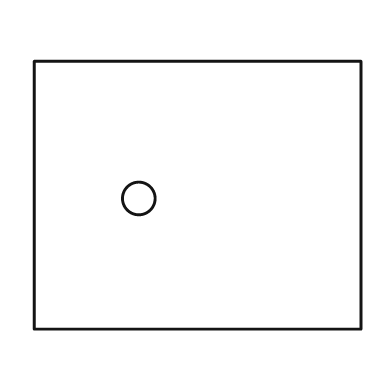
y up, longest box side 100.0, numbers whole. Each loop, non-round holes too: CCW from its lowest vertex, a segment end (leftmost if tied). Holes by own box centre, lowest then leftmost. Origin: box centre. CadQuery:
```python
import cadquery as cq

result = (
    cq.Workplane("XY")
    .moveTo(-50.0, -41.0)
    .lineTo(50.0, -41.0)
    .lineTo(50.0, 41.0)
    .lineTo(-50.0, 41.0)
    .close()
    .moveTo(-18.0, -1.0)
    .circle(5.0)
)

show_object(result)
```